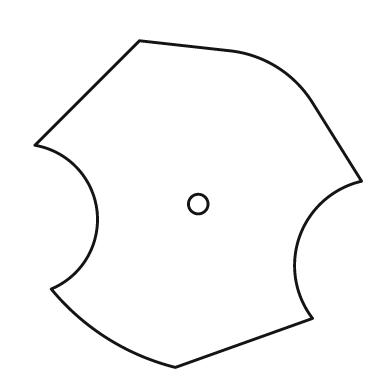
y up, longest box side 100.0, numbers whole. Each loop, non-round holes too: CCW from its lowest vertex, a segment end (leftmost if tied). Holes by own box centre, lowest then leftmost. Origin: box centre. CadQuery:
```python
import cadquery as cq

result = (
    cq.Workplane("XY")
    .moveTo(-7.0, -50.0)
    .lineTo(35.0, -35.0)
    .threePointArc((31.0, -10.0), (50.0, 7.0))
    .lineTo(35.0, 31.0)
    .threePointArc((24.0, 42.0), (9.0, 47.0))
    .lineTo(-18.0, 50.0)
    .lineTo(-50.0, 18.0)
    .threePointArc((-31.0, -2.0), (-45.0, -26.0))
    .threePointArc((-28.0, -41.0), (-7.0, -50.0))
    .close()
    .moveTo(0.0, 0.0)
    .circle(3.0)
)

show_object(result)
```